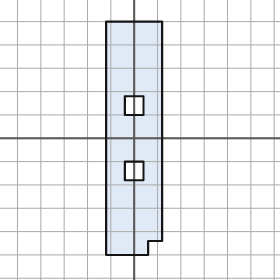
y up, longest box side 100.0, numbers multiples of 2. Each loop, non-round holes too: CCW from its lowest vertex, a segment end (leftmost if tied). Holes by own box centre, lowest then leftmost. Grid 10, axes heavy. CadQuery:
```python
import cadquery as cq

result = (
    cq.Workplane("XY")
    .moveTo(-12.0, -50.0)
    .lineTo(6.0, -50.0)
    .lineTo(6.0, -44.0)
    .lineTo(12.0, -44.0)
    .lineTo(12.0, 50.0)
    .lineTo(-12.0, 50.0)
    .close()
    .moveTo(-4.0, -18.0)
    .lineTo(4.0, -18.0)
    .lineTo(4.0, -10.0)
    .lineTo(-4.0, -10.0)
    .close()
    .moveTo(-4.0, 10.0)
    .lineTo(4.0, 10.0)
    .lineTo(4.0, 18.0)
    .lineTo(-4.0, 18.0)
    .close()
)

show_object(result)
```